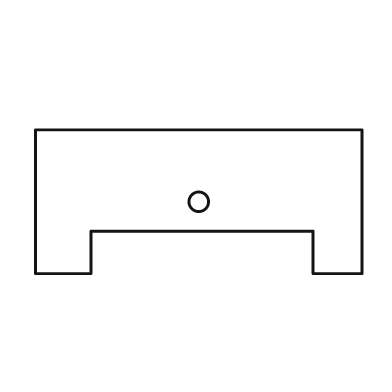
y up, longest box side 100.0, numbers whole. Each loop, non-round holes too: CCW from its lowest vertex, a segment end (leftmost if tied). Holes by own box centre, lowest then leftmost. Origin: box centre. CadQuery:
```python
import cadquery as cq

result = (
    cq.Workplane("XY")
    .moveTo(-50.0, -22.0)
    .lineTo(-33.0, -22.0)
    .lineTo(-33.0, -9.0)
    .lineTo(35.0, -9.0)
    .lineTo(35.0, -22.0)
    .lineTo(50.0, -22.0)
    .lineTo(50.0, 22.0)
    .lineTo(-50.0, 22.0)
    .close()
    .moveTo(0.0, 0.0)
    .circle(3.0)
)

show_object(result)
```